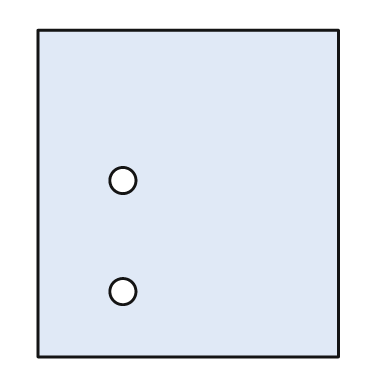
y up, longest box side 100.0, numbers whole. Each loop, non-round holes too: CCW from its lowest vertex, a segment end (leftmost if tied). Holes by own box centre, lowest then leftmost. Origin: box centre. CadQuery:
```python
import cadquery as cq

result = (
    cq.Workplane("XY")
    .moveTo(-46.0, -50.0)
    .lineTo(46.0, -50.0)
    .lineTo(46.0, 50.0)
    .lineTo(-46.0, 50.0)
    .close()
    .moveTo(-20.0, -30.0)
    .circle(4.0)
    .moveTo(-20.0, 4.0)
    .circle(4.0)
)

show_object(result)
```